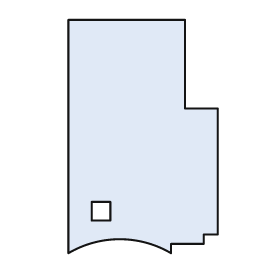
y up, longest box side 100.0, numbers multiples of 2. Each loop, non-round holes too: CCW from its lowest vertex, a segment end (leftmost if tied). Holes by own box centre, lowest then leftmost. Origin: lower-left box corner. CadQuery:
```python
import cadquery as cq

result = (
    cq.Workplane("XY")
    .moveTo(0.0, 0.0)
    .threePointArc((22.0, 6.0), (44.0, 0.0))
    .lineTo(44.0, 4.0)
    .lineTo(58.0, 4.0)
    .lineTo(58.0, 8.0)
    .lineTo(64.0, 8.0)
    .lineTo(64.0, 62.0)
    .lineTo(50.0, 62.0)
    .lineTo(50.0, 100.0)
    .lineTo(0.0, 100.0)
    .close()
    .moveTo(10.0, 14.0)
    .lineTo(18.0, 14.0)
    .lineTo(18.0, 22.0)
    .lineTo(10.0, 22.0)
    .close()
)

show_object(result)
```